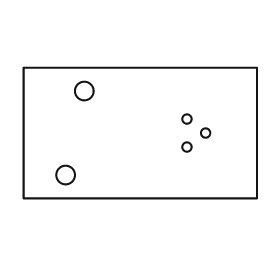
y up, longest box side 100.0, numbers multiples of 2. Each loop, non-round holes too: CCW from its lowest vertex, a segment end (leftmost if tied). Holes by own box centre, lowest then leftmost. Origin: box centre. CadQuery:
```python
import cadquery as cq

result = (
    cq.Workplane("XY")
    .moveTo(-50.0, -28.0)
    .lineTo(50.0, -28.0)
    .lineTo(50.0, 28.0)
    .lineTo(-50.0, 28.0)
    .close()
    .moveTo(-32.0, -18.0)
    .circle(4.0)
    .moveTo(20.0, -6.0)
    .circle(2.0)
    .moveTo(28.0, 0.0)
    .circle(2.0)
    .moveTo(20.0, 6.0)
    .circle(2.0)
    .moveTo(-24.0, 18.0)
    .circle(4.0)
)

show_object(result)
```